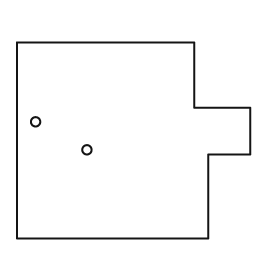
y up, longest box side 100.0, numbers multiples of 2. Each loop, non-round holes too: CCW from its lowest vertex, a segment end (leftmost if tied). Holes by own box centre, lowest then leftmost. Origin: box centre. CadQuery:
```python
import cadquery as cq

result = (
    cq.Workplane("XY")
    .moveTo(-50.0, -42.0)
    .lineTo(32.0, -42.0)
    .lineTo(32.0, -6.0)
    .lineTo(50.0, -6.0)
    .lineTo(50.0, 14.0)
    .lineTo(26.0, 14.0)
    .lineTo(26.0, 42.0)
    .lineTo(-50.0, 42.0)
    .close()
    .moveTo(-20.0, -4.0)
    .circle(2.0)
    .moveTo(-42.0, 8.0)
    .circle(2.0)
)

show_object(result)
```